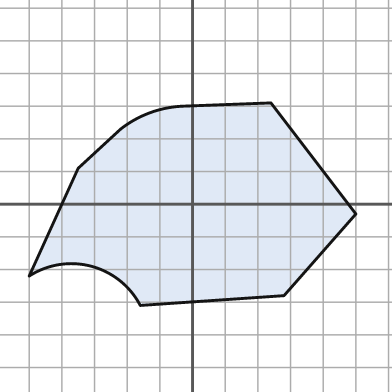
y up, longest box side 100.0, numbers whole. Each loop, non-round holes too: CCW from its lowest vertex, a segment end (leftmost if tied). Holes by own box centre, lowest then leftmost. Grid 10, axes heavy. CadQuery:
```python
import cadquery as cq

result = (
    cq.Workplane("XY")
    .moveTo(-16.0, -31.0)
    .lineTo(28.0, -28.0)
    .lineTo(50.0, -3.0)
    .lineTo(24.0, 31.0)
    .lineTo(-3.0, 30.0)
    .threePointArc((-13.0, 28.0), (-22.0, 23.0))
    .lineTo(-35.0, 11.0)
    .lineTo(-50.0, -22.0)
    .threePointArc((-31.0, -19.0), (-16.0, -31.0))
    .close()
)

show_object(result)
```